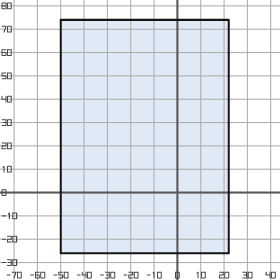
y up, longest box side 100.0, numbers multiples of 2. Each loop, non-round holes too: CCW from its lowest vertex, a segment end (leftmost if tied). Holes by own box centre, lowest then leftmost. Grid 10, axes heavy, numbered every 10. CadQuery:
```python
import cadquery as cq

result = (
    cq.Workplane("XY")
    .moveTo(-50.0, -26.0)
    .lineTo(22.0, -26.0)
    .lineTo(22.0, 74.0)
    .lineTo(-50.0, 74.0)
    .close()
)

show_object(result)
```